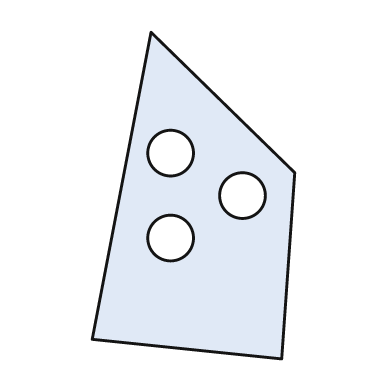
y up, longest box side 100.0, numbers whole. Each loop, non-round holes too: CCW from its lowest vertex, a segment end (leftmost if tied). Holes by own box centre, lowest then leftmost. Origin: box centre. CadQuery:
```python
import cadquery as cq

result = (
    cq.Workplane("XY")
    .moveTo(27.0, -50.0)
    .lineTo(31.0, 7.0)
    .lineTo(-13.0, 50.0)
    .lineTo(-31.0, -44.0)
    .close()
    .moveTo(-7.0, -13.0)
    .circle(7.0)
    .moveTo(15.0, 0.0)
    .circle(7.0)
    .moveTo(-7.0, 13.0)
    .circle(7.0)
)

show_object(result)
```